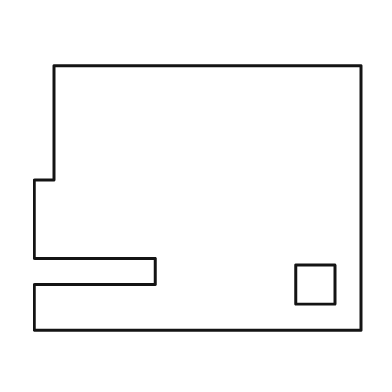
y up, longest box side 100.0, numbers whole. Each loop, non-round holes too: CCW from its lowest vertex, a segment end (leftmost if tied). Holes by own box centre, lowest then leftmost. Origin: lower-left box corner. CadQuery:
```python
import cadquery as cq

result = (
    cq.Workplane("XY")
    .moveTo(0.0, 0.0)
    .lineTo(100.0, 0.0)
    .lineTo(100.0, 81.0)
    .lineTo(6.0, 81.0)
    .lineTo(6.0, 46.0)
    .lineTo(0.0, 46.0)
    .lineTo(0.0, 22.0)
    .lineTo(37.0, 22.0)
    .lineTo(37.0, 14.0)
    .lineTo(0.0, 14.0)
    .close()
    .moveTo(80.0, 8.0)
    .lineTo(92.0, 8.0)
    .lineTo(92.0, 20.0)
    .lineTo(80.0, 20.0)
    .close()
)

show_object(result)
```